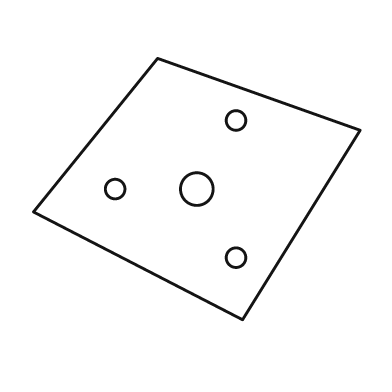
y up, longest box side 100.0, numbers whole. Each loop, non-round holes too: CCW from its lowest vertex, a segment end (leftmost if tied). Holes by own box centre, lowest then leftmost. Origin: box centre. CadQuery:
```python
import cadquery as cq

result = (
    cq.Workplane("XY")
    .moveTo(14.0, -40.0)
    .lineTo(50.0, 18.0)
    .lineTo(-12.0, 40.0)
    .lineTo(-50.0, -7.0)
    .close()
    .moveTo(12.0, -21.0)
    .circle(3.0)
    .moveTo(-25.0, 0.0)
    .circle(3.0)
    .moveTo(0.0, 0.0)
    .circle(5.0)
    .moveTo(12.0, 21.0)
    .circle(3.0)
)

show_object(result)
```